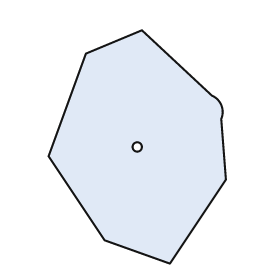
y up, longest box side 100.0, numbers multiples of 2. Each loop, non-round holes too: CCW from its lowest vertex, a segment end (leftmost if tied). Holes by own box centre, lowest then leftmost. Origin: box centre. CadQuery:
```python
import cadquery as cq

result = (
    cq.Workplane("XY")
    .moveTo(14.0, -50.0)
    .lineTo(38.0, -14.0)
    .lineTo(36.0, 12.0)
    .threePointArc((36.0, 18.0), (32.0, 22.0))
    .lineTo(2.0, 50.0)
    .lineTo(-22.0, 40.0)
    .lineTo(-38.0, -4.0)
    .lineTo(-14.0, -40.0)
    .close()
    .moveTo(0.0, 0.0)
    .circle(2.0)
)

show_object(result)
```